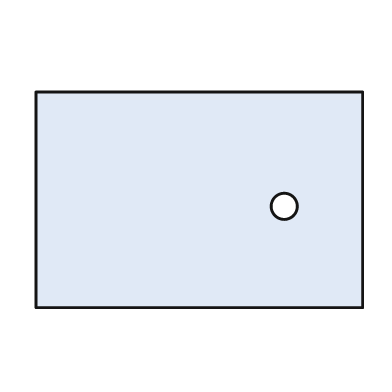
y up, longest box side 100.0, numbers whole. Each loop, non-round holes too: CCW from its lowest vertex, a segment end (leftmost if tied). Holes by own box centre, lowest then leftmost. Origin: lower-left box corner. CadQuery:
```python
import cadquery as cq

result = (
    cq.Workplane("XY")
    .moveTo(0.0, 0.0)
    .lineTo(100.0, 0.0)
    .lineTo(100.0, 66.0)
    .lineTo(0.0, 66.0)
    .close()
    .moveTo(76.0, 31.0)
    .circle(4.0)
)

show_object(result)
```